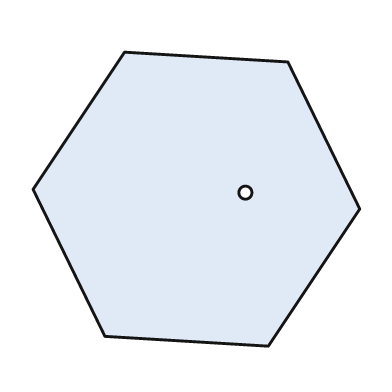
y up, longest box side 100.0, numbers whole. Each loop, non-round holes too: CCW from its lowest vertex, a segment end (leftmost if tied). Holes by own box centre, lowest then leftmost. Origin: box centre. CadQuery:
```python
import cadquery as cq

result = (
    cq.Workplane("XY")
    .moveTo(22.0, -45.0)
    .lineTo(50.0, -3.0)
    .lineTo(28.0, 42.0)
    .lineTo(-22.0, 45.0)
    .lineTo(-50.0, 3.0)
    .lineTo(-28.0, -42.0)
    .close()
    .moveTo(15.0, 2.0)
    .circle(2.0)
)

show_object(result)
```